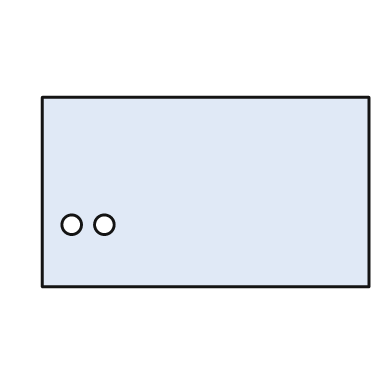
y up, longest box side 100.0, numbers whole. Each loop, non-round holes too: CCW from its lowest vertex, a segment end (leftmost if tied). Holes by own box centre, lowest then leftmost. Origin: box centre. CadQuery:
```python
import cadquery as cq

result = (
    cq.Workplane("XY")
    .moveTo(-50.0, -29.0)
    .lineTo(50.0, -29.0)
    .lineTo(50.0, 29.0)
    .lineTo(-50.0, 29.0)
    .close()
    .moveTo(-41.0, -10.0)
    .circle(3.0)
    .moveTo(-31.0, -10.0)
    .circle(3.0)
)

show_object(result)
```